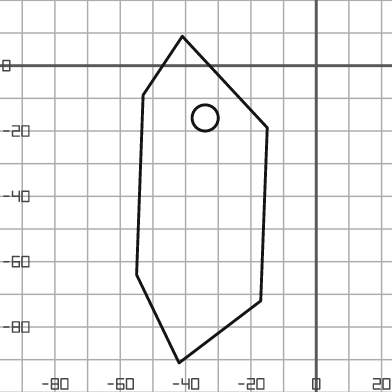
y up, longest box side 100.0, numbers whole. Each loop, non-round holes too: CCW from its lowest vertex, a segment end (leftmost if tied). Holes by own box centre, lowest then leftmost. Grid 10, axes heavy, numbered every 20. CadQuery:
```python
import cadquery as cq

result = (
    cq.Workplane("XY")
    .moveTo(-42.0, -91.0)
    .lineTo(-17.0, -72.0)
    .lineTo(-15.0, -19.0)
    .lineTo(-41.0, 9.0)
    .lineTo(-53.0, -9.0)
    .lineTo(-55.0, -64.0)
    .close()
    .moveTo(-34.0, -16.0)
    .circle(4.0)
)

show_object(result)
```